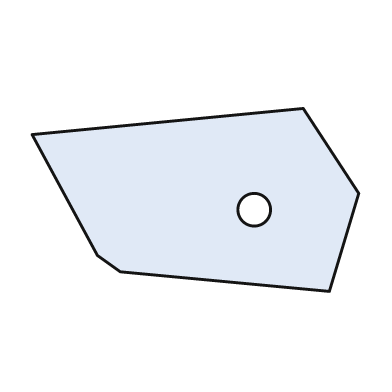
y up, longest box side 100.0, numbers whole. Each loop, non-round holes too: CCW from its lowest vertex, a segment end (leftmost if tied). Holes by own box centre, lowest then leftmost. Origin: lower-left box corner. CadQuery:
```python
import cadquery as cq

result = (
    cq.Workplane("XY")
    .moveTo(91.0, 0.0)
    .lineTo(100.0, 30.0)
    .lineTo(83.0, 56.0)
    .lineTo(0.0, 48.0)
    .lineTo(20.0, 11.0)
    .lineTo(27.0, 6.0)
    .close()
    .moveTo(68.0, 25.0)
    .circle(5.0)
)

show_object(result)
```